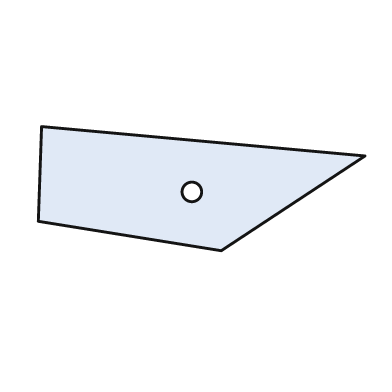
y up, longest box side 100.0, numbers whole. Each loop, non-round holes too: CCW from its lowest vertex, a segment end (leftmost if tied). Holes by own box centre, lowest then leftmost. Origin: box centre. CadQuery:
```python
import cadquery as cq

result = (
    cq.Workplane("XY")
    .moveTo(6.0, -19.0)
    .lineTo(50.0, 10.0)
    .lineTo(-49.0, 19.0)
    .lineTo(-50.0, -10.0)
    .close()
    .moveTo(-3.0, -1.0)
    .circle(3.0)
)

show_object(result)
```